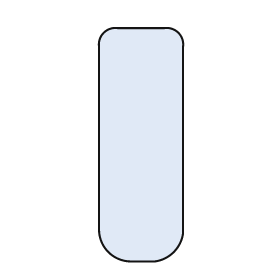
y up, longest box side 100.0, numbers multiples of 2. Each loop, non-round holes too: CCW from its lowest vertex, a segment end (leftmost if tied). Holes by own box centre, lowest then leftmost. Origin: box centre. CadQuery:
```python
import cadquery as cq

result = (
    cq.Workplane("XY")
    .moveTo(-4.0, -50.0)
    .lineTo(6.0, -50.0)
    .threePointArc((14.0, -46.0), (18.0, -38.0))
    .lineTo(18.0, 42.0)
    .threePointArc((16.0, 48.0), (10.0, 50.0))
    .lineTo(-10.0, 50.0)
    .threePointArc((-16.0, 48.0), (-18.0, 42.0))
    .lineTo(-18.0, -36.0)
    .threePointArc((-14.0, -46.0), (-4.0, -50.0))
    .close()
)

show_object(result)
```